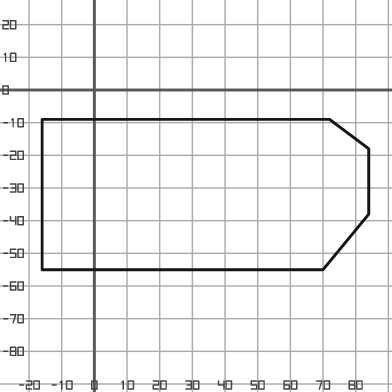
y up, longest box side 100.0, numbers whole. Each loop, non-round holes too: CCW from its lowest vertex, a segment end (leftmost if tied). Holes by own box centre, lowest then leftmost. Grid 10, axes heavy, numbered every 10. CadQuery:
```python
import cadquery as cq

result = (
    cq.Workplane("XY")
    .moveTo(-16.0, -55.0)
    .lineTo(70.0, -55.0)
    .lineTo(84.0, -38.0)
    .lineTo(84.0, -18.0)
    .lineTo(72.0, -9.0)
    .lineTo(-16.0, -9.0)
    .close()
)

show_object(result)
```